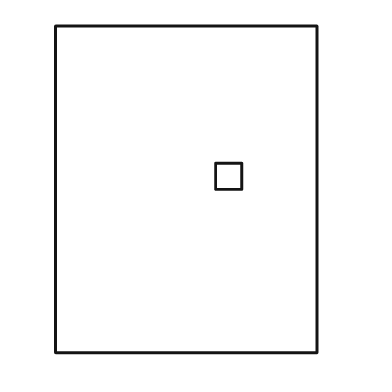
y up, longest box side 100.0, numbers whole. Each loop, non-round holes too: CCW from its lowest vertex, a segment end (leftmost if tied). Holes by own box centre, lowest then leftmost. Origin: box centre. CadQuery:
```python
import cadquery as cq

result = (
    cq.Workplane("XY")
    .moveTo(-40.0, -50.0)
    .lineTo(40.0, -50.0)
    .lineTo(40.0, 50.0)
    .lineTo(-40.0, 50.0)
    .close()
    .moveTo(9.0, 0.0)
    .lineTo(17.0, 0.0)
    .lineTo(17.0, 8.0)
    .lineTo(9.0, 8.0)
    .close()
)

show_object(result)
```